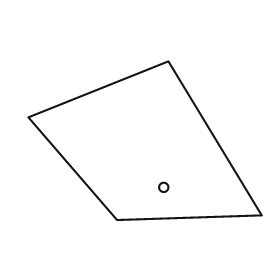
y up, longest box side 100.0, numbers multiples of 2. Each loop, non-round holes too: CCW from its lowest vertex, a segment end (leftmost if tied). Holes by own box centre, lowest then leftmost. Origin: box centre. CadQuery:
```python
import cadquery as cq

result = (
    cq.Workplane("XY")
    .moveTo(-12.0, -34.0)
    .lineTo(50.0, -32.0)
    .lineTo(10.0, 34.0)
    .lineTo(-50.0, 10.0)
    .close()
    .moveTo(8.0, -20.0)
    .circle(2.0)
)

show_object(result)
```